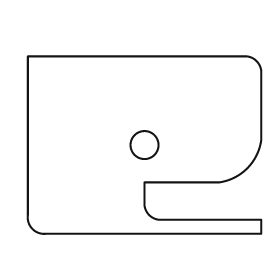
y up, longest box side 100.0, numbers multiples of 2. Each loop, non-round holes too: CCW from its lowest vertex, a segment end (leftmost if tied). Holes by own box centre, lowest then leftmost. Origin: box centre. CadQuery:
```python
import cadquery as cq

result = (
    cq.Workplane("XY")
    .moveTo(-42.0, -38.0)
    .lineTo(50.0, -38.0)
    .lineTo(50.0, -32.0)
    .lineTo(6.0, -32.0)
    .threePointArc((2.0, -30.0), (0.0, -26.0))
    .lineTo(0.0, -16.0)
    .lineTo(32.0, -16.0)
    .threePointArc((44.0, -10.0), (50.0, 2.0))
    .lineTo(50.0, 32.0)
    .threePointArc((48.0, 36.0), (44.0, 38.0))
    .lineTo(-50.0, 38.0)
    .lineTo(-50.0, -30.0)
    .threePointArc((-48.0, -36.0), (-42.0, -38.0))
    .close()
    .moveTo(0.0, 0.0)
    .circle(6.0)
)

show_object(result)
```